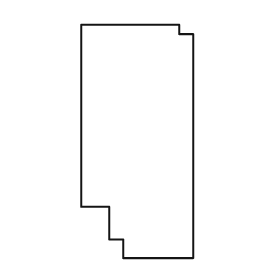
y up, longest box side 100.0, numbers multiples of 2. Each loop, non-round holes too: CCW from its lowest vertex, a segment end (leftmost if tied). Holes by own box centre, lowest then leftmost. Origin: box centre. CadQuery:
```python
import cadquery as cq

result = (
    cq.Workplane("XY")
    .moveTo(-6.0, -50.0)
    .lineTo(24.0, -50.0)
    .lineTo(24.0, 46.0)
    .lineTo(18.0, 46.0)
    .lineTo(18.0, 50.0)
    .lineTo(-24.0, 50.0)
    .lineTo(-24.0, -28.0)
    .lineTo(-12.0, -28.0)
    .lineTo(-12.0, -42.0)
    .lineTo(-6.0, -42.0)
    .close()
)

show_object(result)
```